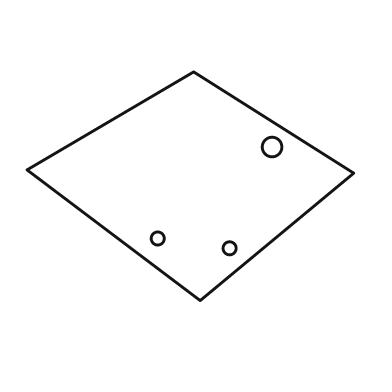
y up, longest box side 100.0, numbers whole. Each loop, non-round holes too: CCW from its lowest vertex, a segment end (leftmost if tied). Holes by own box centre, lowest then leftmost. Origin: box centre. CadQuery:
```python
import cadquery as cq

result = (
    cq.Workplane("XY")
    .moveTo(3.0, -35.0)
    .lineTo(50.0, 4.0)
    .lineTo(1.0, 35.0)
    .lineTo(-50.0, 5.0)
    .close()
    .moveTo(12.0, -19.0)
    .circle(2.0)
    .moveTo(-10.0, -16.0)
    .circle(2.0)
    .moveTo(25.0, 12.0)
    .circle(3.0)
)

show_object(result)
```